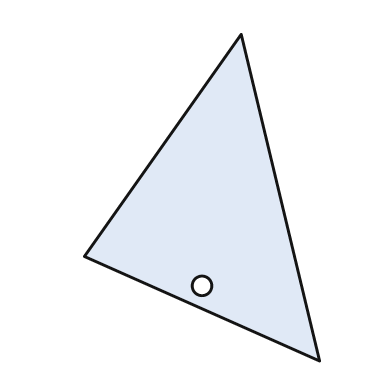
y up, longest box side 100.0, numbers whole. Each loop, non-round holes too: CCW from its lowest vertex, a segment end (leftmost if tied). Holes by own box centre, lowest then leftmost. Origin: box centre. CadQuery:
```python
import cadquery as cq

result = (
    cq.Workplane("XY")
    .moveTo(36.0, -50.0)
    .lineTo(12.0, 50.0)
    .lineTo(-36.0, -18.0)
    .close()
    .moveTo(0.0, -27.0)
    .circle(3.0)
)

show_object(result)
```